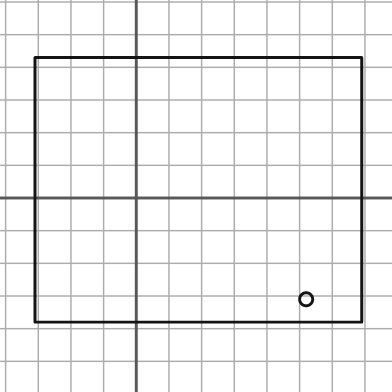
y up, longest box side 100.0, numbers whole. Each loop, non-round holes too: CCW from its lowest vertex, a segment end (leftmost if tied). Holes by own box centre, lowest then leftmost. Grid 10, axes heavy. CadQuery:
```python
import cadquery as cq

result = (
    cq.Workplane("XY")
    .moveTo(-31.0, -38.0)
    .lineTo(69.0, -38.0)
    .lineTo(69.0, 43.0)
    .lineTo(-31.0, 43.0)
    .close()
    .moveTo(52.0, -31.0)
    .circle(2.0)
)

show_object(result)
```